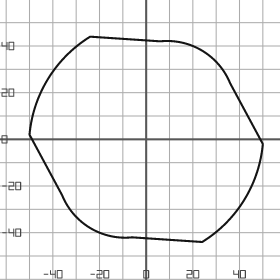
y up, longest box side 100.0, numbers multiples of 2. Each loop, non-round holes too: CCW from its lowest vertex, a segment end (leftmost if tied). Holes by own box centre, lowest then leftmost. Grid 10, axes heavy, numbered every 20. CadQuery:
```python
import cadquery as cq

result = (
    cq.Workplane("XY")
    .moveTo(24.0, -44.0)
    .threePointArc((42.0, -26.0), (50.0, -2.0))
    .lineTo(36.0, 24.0)
    .threePointArc((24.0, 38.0), (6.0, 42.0))
    .lineTo(-24.0, 44.0)
    .threePointArc((-42.0, 26.0), (-50.0, 2.0))
    .lineTo(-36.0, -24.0)
    .threePointArc((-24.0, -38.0), (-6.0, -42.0))
    .close()
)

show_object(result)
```